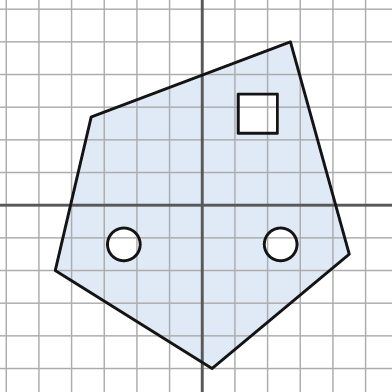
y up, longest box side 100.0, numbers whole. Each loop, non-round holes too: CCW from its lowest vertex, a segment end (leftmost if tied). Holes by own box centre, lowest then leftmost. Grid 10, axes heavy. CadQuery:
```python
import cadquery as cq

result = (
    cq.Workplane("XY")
    .moveTo(3.0, -50.0)
    .lineTo(45.0, -15.0)
    .lineTo(27.0, 50.0)
    .lineTo(-34.0, 27.0)
    .lineTo(-45.0, -20.0)
    .close()
    .moveTo(-24.0, -12.0)
    .circle(5.0)
    .moveTo(24.0, -12.0)
    .circle(5.0)
    .moveTo(11.0, 22.0)
    .lineTo(23.0, 22.0)
    .lineTo(23.0, 34.0)
    .lineTo(11.0, 34.0)
    .close()
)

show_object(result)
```